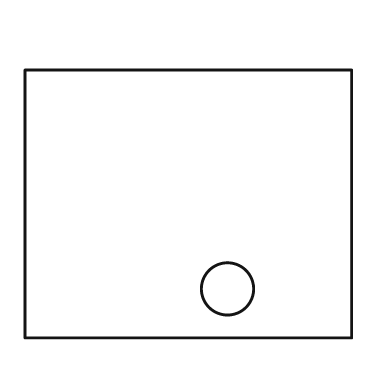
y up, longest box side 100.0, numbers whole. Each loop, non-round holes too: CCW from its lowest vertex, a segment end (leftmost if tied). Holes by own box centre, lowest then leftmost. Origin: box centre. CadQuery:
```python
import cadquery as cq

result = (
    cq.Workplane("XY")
    .moveTo(-50.0, -41.0)
    .lineTo(50.0, -41.0)
    .lineTo(50.0, 41.0)
    .lineTo(-50.0, 41.0)
    .close()
    .moveTo(12.0, -26.0)
    .circle(8.0)
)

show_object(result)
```